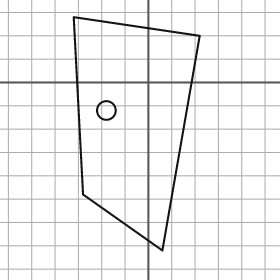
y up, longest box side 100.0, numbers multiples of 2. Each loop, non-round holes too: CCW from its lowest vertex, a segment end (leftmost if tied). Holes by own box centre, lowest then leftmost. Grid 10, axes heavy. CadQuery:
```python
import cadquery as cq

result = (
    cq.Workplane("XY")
    .moveTo(6.0, -72.0)
    .lineTo(22.0, 20.0)
    .lineTo(-32.0, 28.0)
    .lineTo(-28.0, -48.0)
    .close()
    .moveTo(-18.0, -12.0)
    .circle(4.0)
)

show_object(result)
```